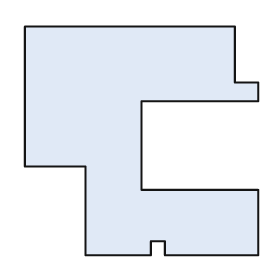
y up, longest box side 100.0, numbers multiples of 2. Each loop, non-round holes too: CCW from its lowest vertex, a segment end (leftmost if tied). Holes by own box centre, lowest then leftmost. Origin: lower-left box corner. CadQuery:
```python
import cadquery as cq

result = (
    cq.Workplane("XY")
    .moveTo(26.0, 0.0)
    .lineTo(54.0, 0.0)
    .lineTo(54.0, 6.0)
    .lineTo(60.0, 6.0)
    .lineTo(60.0, 0.0)
    .lineTo(100.0, 0.0)
    .lineTo(100.0, 28.0)
    .lineTo(50.0, 28.0)
    .lineTo(50.0, 66.0)
    .lineTo(100.0, 66.0)
    .lineTo(100.0, 74.0)
    .lineTo(90.0, 74.0)
    .lineTo(90.0, 98.0)
    .lineTo(0.0, 98.0)
    .lineTo(0.0, 38.0)
    .lineTo(26.0, 38.0)
    .close()
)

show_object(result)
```